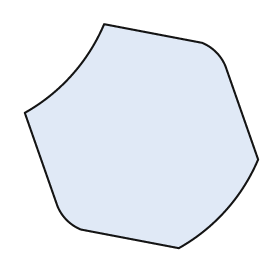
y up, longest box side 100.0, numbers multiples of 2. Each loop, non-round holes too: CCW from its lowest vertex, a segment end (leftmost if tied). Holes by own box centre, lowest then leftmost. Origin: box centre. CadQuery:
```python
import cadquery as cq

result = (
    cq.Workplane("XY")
    .moveTo(16.0, -48.0)
    .threePointArc((36.0, -32.0), (50.0, -10.0))
    .lineTo(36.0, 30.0)
    .threePointArc((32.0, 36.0), (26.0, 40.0))
    .lineTo(-16.0, 48.0)
    .threePointArc((-30.0, 26.0), (-50.0, 10.0))
    .lineTo(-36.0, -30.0)
    .threePointArc((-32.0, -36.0), (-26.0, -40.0))
    .close()
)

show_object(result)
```